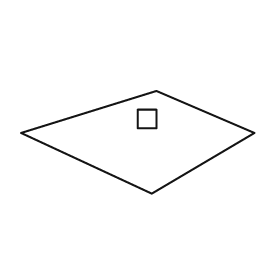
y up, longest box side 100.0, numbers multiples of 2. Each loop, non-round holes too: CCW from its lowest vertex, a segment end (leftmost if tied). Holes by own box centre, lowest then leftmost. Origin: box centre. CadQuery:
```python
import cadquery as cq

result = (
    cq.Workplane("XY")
    .moveTo(6.0, -22.0)
    .lineTo(50.0, 4.0)
    .lineTo(8.0, 22.0)
    .lineTo(-50.0, 4.0)
    .close()
    .moveTo(0.0, 6.0)
    .lineTo(8.0, 6.0)
    .lineTo(8.0, 14.0)
    .lineTo(0.0, 14.0)
    .close()
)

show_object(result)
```